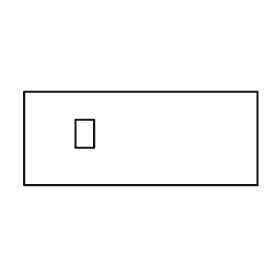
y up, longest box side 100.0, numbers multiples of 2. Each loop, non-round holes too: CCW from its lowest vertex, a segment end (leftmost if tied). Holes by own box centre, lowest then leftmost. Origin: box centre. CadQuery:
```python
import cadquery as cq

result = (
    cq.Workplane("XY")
    .moveTo(-50.0, -20.0)
    .lineTo(50.0, -20.0)
    .lineTo(50.0, 20.0)
    .lineTo(-50.0, 20.0)
    .close()
    .moveTo(-28.0, -4.0)
    .lineTo(-20.0, -4.0)
    .lineTo(-20.0, 8.0)
    .lineTo(-28.0, 8.0)
    .close()
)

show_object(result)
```